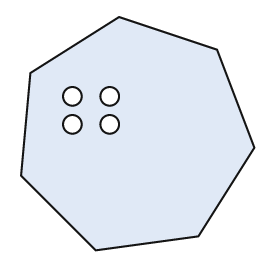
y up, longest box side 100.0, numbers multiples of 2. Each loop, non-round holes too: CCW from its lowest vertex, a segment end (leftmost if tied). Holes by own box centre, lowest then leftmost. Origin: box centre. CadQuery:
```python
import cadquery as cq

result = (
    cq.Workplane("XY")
    .moveTo(-18.0, -50.0)
    .lineTo(26.0, -44.0)
    .lineTo(50.0, -6.0)
    .lineTo(34.0, 36.0)
    .lineTo(-8.0, 50.0)
    .lineTo(-46.0, 26.0)
    .lineTo(-50.0, -18.0)
    .close()
    .moveTo(-28.0, 4.0)
    .circle(4.0)
    .moveTo(-12.0, 4.0)
    .circle(4.0)
    .moveTo(-28.0, 16.0)
    .circle(4.0)
    .moveTo(-12.0, 16.0)
    .circle(4.0)
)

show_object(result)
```